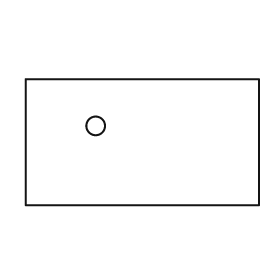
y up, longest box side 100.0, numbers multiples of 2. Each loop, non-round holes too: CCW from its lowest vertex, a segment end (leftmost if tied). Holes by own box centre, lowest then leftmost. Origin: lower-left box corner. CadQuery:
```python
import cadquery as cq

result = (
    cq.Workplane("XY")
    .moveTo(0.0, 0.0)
    .lineTo(100.0, 0.0)
    .lineTo(100.0, 54.0)
    .lineTo(0.0, 54.0)
    .close()
    .moveTo(30.0, 34.0)
    .circle(4.0)
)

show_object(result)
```